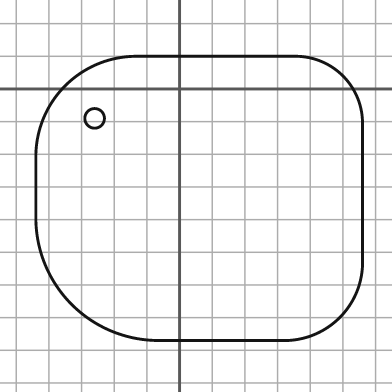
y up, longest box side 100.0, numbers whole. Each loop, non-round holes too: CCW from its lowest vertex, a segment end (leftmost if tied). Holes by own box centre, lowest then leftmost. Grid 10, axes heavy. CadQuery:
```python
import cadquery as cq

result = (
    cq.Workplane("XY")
    .moveTo(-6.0, -77.0)
    .lineTo(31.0, -77.0)
    .threePointArc((49.0, -70.0), (56.0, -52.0))
    .lineTo(56.0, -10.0)
    .threePointArc((50.0, 4.0), (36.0, 10.0))
    .lineTo(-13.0, 10.0)
    .threePointArc((-35.0, 1.0), (-44.0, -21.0))
    .lineTo(-44.0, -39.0)
    .threePointArc((-33.0, -66.0), (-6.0, -77.0))
    .close()
    .moveTo(-26.0, -9.0)
    .circle(3.0)
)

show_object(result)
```